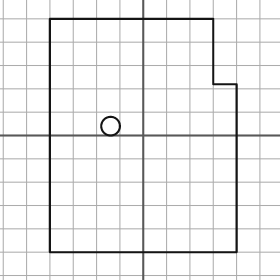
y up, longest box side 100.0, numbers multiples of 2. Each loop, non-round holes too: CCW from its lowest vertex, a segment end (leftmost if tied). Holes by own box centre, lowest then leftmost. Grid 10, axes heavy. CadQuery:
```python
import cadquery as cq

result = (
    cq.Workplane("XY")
    .moveTo(-40.0, -50.0)
    .lineTo(40.0, -50.0)
    .lineTo(40.0, 22.0)
    .lineTo(30.0, 22.0)
    .lineTo(30.0, 50.0)
    .lineTo(-40.0, 50.0)
    .close()
    .moveTo(-14.0, 4.0)
    .circle(4.0)
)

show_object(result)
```